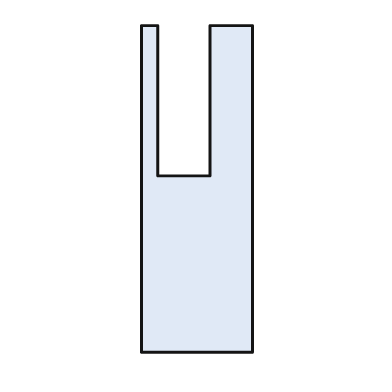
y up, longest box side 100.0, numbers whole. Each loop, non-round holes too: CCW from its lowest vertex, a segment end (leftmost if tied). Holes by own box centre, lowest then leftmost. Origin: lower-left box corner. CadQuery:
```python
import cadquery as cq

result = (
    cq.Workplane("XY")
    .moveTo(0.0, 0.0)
    .lineTo(34.0, 0.0)
    .lineTo(34.0, 100.0)
    .lineTo(21.0, 100.0)
    .lineTo(21.0, 54.0)
    .lineTo(5.0, 54.0)
    .lineTo(5.0, 100.0)
    .lineTo(0.0, 100.0)
    .close()
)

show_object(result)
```